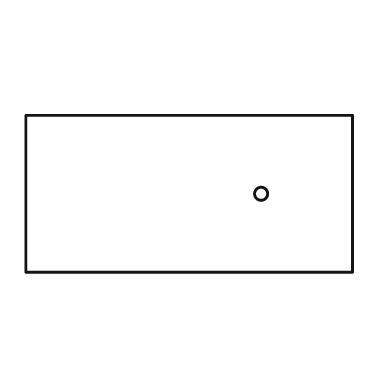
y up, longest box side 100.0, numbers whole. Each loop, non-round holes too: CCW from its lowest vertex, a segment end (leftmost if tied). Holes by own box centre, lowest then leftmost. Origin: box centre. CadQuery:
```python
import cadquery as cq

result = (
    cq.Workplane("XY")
    .moveTo(-50.0, -24.0)
    .lineTo(50.0, -24.0)
    .lineTo(50.0, 24.0)
    .lineTo(-50.0, 24.0)
    .close()
    .moveTo(22.0, 0.0)
    .circle(2.0)
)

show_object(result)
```